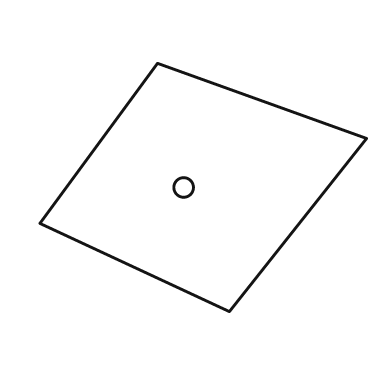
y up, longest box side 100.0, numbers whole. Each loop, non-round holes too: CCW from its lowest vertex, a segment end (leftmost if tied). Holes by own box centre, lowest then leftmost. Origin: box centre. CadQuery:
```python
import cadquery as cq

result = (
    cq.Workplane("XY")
    .moveTo(8.0, -38.0)
    .lineTo(50.0, 15.0)
    .lineTo(-14.0, 38.0)
    .lineTo(-50.0, -11.0)
    .close()
    .moveTo(-6.0, 0.0)
    .circle(3.0)
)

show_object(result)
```